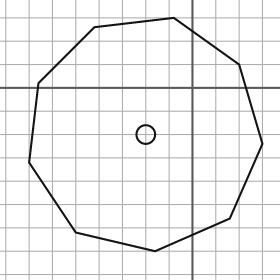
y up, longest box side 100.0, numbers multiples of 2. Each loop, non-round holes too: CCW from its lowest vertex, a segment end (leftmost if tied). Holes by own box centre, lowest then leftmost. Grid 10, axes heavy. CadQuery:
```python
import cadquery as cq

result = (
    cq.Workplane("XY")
    .moveTo(-16.0, -70.0)
    .lineTo(16.0, -56.0)
    .lineTo(30.0, -24.0)
    .lineTo(20.0, 10.0)
    .lineTo(-8.0, 30.0)
    .lineTo(-42.0, 26.0)
    .lineTo(-66.0, 2.0)
    .lineTo(-70.0, -32.0)
    .lineTo(-50.0, -62.0)
    .close()
    .moveTo(-20.0, -20.0)
    .circle(4.0)
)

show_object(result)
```